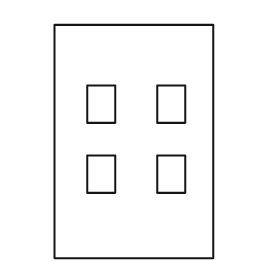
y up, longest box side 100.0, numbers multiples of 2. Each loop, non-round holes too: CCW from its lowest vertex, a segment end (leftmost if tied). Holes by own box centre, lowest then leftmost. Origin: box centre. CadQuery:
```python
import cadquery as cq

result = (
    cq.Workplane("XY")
    .moveTo(-34.0, -50.0)
    .lineTo(34.0, -50.0)
    .lineTo(34.0, 50.0)
    .lineTo(-34.0, 50.0)
    .close()
    .moveTo(-20.0, -22.0)
    .lineTo(-8.0, -22.0)
    .lineTo(-8.0, -6.0)
    .lineTo(-20.0, -6.0)
    .close()
    .moveTo(10.0, -22.0)
    .lineTo(22.0, -22.0)
    .lineTo(22.0, -6.0)
    .lineTo(10.0, -6.0)
    .close()
    .moveTo(-20.0, 8.0)
    .lineTo(-8.0, 8.0)
    .lineTo(-8.0, 24.0)
    .lineTo(-20.0, 24.0)
    .close()
    .moveTo(10.0, 8.0)
    .lineTo(22.0, 8.0)
    .lineTo(22.0, 24.0)
    .lineTo(10.0, 24.0)
    .close()
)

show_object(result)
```